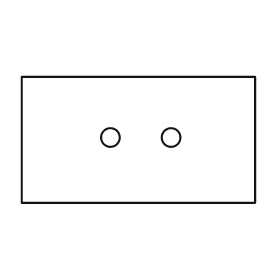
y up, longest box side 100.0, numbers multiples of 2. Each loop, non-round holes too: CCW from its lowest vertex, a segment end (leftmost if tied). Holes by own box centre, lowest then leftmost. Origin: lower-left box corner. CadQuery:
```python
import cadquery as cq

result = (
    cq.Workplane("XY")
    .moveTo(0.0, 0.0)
    .lineTo(100.0, 0.0)
    .lineTo(100.0, 54.0)
    .lineTo(0.0, 54.0)
    .close()
    .moveTo(38.0, 28.0)
    .circle(4.0)
    .moveTo(64.0, 28.0)
    .circle(4.0)
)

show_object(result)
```